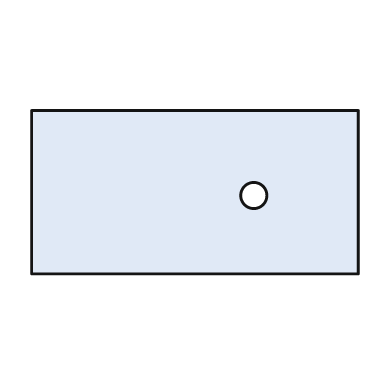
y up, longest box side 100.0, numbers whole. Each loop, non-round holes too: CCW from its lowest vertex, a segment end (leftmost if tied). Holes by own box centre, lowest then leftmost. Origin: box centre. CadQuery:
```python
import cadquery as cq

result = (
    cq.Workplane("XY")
    .moveTo(-50.0, -25.0)
    .lineTo(50.0, -25.0)
    .lineTo(50.0, 25.0)
    .lineTo(-50.0, 25.0)
    .close()
    .moveTo(18.0, -1.0)
    .circle(4.0)
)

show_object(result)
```